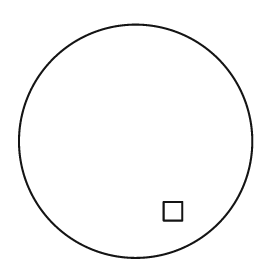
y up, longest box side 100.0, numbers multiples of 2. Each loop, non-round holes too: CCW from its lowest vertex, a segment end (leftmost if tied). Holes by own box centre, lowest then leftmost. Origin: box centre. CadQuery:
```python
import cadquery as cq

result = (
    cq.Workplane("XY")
    .moveTo(0.0, 0.0)
    .circle(50.0)
    .moveTo(12.0, -34.0)
    .lineTo(20.0, -34.0)
    .lineTo(20.0, -26.0)
    .lineTo(12.0, -26.0)
    .close()
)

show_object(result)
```